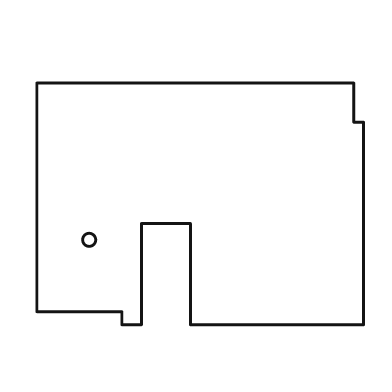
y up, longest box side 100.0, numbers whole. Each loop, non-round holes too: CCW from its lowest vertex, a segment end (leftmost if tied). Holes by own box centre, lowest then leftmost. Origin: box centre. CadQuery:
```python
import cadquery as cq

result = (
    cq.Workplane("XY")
    .moveTo(-24.0, -37.0)
    .lineTo(-18.0, -37.0)
    .lineTo(-18.0, -6.0)
    .lineTo(-3.0, -6.0)
    .lineTo(-3.0, -37.0)
    .lineTo(50.0, -37.0)
    .lineTo(50.0, 25.0)
    .lineTo(47.0, 25.0)
    .lineTo(47.0, 37.0)
    .lineTo(-50.0, 37.0)
    .lineTo(-50.0, -33.0)
    .lineTo(-24.0, -33.0)
    .close()
    .moveTo(-34.0, -11.0)
    .circle(2.0)
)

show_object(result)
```